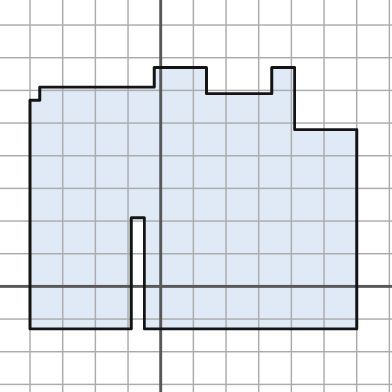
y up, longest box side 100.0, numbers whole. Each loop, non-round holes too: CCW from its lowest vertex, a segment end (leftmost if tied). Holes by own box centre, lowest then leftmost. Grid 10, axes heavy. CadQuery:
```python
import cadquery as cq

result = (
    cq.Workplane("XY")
    .moveTo(-40.0, -13.0)
    .lineTo(-9.0, -13.0)
    .lineTo(-9.0, 21.0)
    .lineTo(-5.0, 21.0)
    .lineTo(-5.0, -13.0)
    .lineTo(60.0, -13.0)
    .lineTo(60.0, 48.0)
    .lineTo(41.0, 48.0)
    .lineTo(41.0, 67.0)
    .lineTo(34.0, 67.0)
    .lineTo(34.0, 59.0)
    .lineTo(14.0, 59.0)
    .lineTo(14.0, 67.0)
    .lineTo(-2.0, 67.0)
    .lineTo(-2.0, 61.0)
    .lineTo(-37.0, 61.0)
    .lineTo(-37.0, 57.0)
    .lineTo(-40.0, 57.0)
    .close()
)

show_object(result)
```